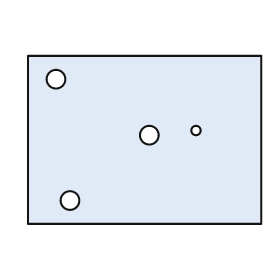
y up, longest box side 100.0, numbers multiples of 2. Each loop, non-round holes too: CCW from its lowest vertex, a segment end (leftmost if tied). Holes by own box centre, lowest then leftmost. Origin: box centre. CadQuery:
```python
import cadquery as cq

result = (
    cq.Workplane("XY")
    .moveTo(-50.0, -36.0)
    .lineTo(50.0, -36.0)
    .lineTo(50.0, 36.0)
    .lineTo(-50.0, 36.0)
    .close()
    .moveTo(-32.0, -26.0)
    .circle(4.0)
    .moveTo(2.0, 2.0)
    .circle(4.0)
    .moveTo(22.0, 4.0)
    .circle(2.0)
    .moveTo(-38.0, 26.0)
    .circle(4.0)
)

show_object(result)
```